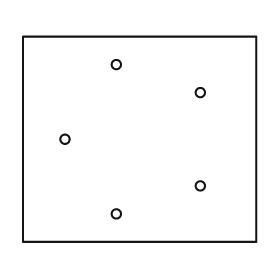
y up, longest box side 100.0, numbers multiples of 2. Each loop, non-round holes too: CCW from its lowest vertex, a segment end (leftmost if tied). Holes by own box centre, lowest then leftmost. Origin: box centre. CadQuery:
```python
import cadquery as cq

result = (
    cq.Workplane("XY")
    .moveTo(-50.0, -44.0)
    .lineTo(50.0, -44.0)
    .lineTo(50.0, 44.0)
    .lineTo(-50.0, 44.0)
    .close()
    .moveTo(-10.0, -32.0)
    .circle(2.0)
    .moveTo(26.0, -20.0)
    .circle(2.0)
    .moveTo(-32.0, 0.0)
    .circle(2.0)
    .moveTo(26.0, 20.0)
    .circle(2.0)
    .moveTo(-10.0, 32.0)
    .circle(2.0)
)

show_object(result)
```